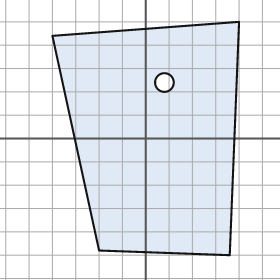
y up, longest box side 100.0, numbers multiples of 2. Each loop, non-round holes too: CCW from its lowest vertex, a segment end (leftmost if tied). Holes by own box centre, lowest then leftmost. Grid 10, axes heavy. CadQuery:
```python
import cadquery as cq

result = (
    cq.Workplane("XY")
    .moveTo(36.0, -50.0)
    .lineTo(40.0, 50.0)
    .lineTo(-40.0, 44.0)
    .lineTo(-20.0, -48.0)
    .close()
    .moveTo(8.0, 24.0)
    .circle(4.0)
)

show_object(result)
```